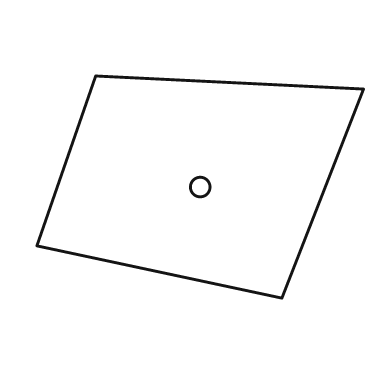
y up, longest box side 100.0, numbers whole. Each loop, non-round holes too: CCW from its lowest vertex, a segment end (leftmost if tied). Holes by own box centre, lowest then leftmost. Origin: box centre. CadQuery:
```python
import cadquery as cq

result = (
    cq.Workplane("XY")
    .moveTo(25.0, -34.0)
    .lineTo(50.0, 30.0)
    .lineTo(-32.0, 34.0)
    .lineTo(-50.0, -18.0)
    .close()
    .moveTo(0.0, 0.0)
    .circle(3.0)
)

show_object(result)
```